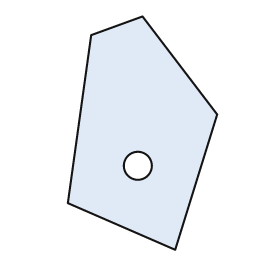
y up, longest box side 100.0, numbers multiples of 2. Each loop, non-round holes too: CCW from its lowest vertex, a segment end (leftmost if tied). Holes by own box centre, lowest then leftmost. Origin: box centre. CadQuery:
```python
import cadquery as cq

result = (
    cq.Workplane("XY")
    .moveTo(14.0, -50.0)
    .lineTo(32.0, 8.0)
    .lineTo(0.0, 50.0)
    .lineTo(-22.0, 42.0)
    .lineTo(-32.0, -30.0)
    .close()
    .moveTo(-2.0, -14.0)
    .circle(6.0)
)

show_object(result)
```